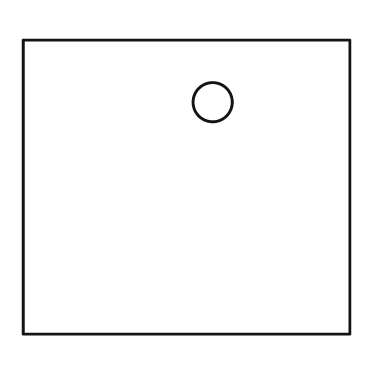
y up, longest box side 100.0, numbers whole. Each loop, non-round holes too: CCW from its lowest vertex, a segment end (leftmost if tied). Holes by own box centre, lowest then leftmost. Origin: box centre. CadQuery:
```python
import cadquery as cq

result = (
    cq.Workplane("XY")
    .moveTo(-50.0, -45.0)
    .lineTo(50.0, -45.0)
    .lineTo(50.0, 45.0)
    .lineTo(-50.0, 45.0)
    .close()
    .moveTo(8.0, 26.0)
    .circle(6.0)
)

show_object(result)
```